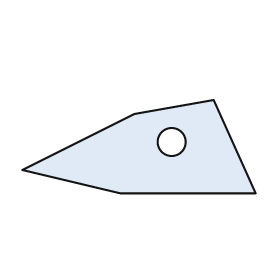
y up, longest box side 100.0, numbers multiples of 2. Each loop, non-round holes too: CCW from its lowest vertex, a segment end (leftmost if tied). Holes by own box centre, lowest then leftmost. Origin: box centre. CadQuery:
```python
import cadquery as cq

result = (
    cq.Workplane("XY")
    .moveTo(-8.0, -20.0)
    .lineTo(50.0, -20.0)
    .lineTo(32.0, 20.0)
    .lineTo(-2.0, 14.0)
    .lineTo(-50.0, -10.0)
    .close()
    .moveTo(14.0, 2.0)
    .circle(6.0)
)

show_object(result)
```